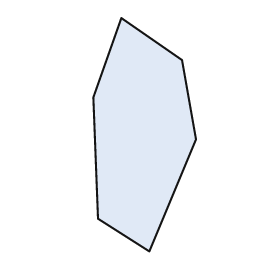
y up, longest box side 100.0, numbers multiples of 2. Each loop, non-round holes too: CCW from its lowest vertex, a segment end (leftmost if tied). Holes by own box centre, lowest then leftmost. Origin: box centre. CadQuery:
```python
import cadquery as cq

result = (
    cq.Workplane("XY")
    .moveTo(2.0, -50.0)
    .lineTo(22.0, -2.0)
    .lineTo(16.0, 32.0)
    .lineTo(-10.0, 50.0)
    .lineTo(-22.0, 16.0)
    .lineTo(-20.0, -36.0)
    .close()
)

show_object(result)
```